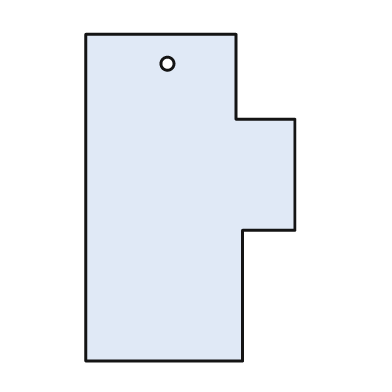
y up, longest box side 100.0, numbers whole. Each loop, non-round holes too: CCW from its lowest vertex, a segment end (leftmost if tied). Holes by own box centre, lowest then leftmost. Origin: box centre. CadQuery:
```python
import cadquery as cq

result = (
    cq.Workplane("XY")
    .moveTo(-32.0, -50.0)
    .lineTo(16.0, -50.0)
    .lineTo(16.0, -10.0)
    .lineTo(32.0, -10.0)
    .lineTo(32.0, 24.0)
    .lineTo(14.0, 24.0)
    .lineTo(14.0, 50.0)
    .lineTo(-32.0, 50.0)
    .close()
    .moveTo(-7.0, 41.0)
    .circle(2.0)
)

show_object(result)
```